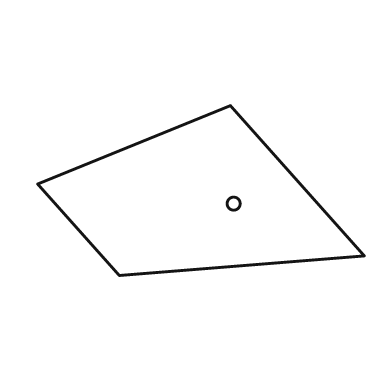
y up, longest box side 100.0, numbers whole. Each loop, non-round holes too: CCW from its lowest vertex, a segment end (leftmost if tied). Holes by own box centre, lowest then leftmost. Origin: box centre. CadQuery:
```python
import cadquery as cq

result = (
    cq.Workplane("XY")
    .moveTo(-25.0, -26.0)
    .lineTo(50.0, -20.0)
    .lineTo(9.0, 26.0)
    .lineTo(-50.0, 2.0)
    .close()
    .moveTo(10.0, -4.0)
    .circle(2.0)
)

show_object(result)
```